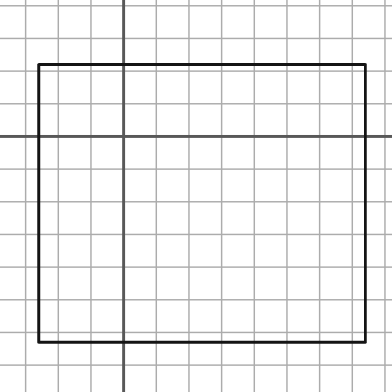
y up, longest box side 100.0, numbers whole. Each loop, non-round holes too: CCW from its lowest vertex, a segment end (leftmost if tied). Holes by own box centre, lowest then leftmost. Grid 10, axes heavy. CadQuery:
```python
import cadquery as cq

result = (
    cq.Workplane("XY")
    .moveTo(-26.0, -63.0)
    .lineTo(74.0, -63.0)
    .lineTo(74.0, 22.0)
    .lineTo(-26.0, 22.0)
    .close()
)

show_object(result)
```